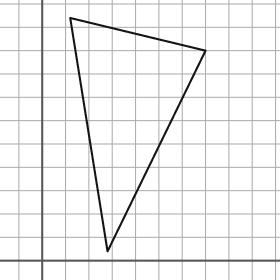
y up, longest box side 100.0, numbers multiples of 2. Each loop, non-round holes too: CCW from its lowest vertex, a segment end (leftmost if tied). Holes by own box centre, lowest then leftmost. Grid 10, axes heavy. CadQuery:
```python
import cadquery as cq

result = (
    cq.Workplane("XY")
    .moveTo(28.0, 4.0)
    .lineTo(70.0, 90.0)
    .lineTo(12.0, 104.0)
    .close()
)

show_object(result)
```